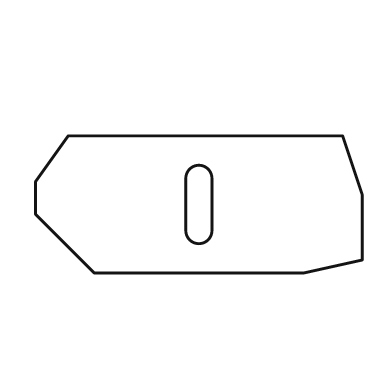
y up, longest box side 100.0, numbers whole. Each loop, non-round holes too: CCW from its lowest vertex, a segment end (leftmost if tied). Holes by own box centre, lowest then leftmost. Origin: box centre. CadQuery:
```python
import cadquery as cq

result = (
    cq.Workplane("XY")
    .moveTo(-32.0, -21.0)
    .lineTo(32.0, -21.0)
    .lineTo(50.0, -17.0)
    .lineTo(50.0, 3.0)
    .lineTo(44.0, 21.0)
    .lineTo(-40.0, 21.0)
    .lineTo(-50.0, 7.0)
    .lineTo(-50.0, -3.0)
    .close()
    .moveTo(-4.0, -8.0)
    .threePointArc((0.0, -12.0), (4.0, -8.0))
    .lineTo(4.0, 8.0)
    .threePointArc((0.0, 12.0), (-4.0, 8.0))
    .close()
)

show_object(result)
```